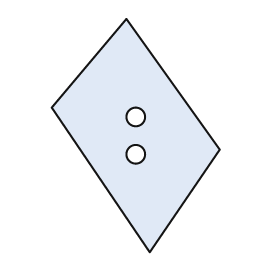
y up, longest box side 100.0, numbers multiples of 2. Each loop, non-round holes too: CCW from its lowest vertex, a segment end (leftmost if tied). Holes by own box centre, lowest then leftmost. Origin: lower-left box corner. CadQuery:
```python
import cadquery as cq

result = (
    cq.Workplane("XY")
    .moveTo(42.0, 0.0)
    .lineTo(72.0, 44.0)
    .lineTo(32.0, 100.0)
    .lineTo(0.0, 62.0)
    .close()
    .moveTo(36.0, 42.0)
    .circle(4.0)
    .moveTo(36.0, 58.0)
    .circle(4.0)
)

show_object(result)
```